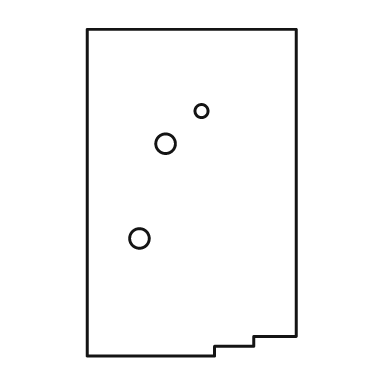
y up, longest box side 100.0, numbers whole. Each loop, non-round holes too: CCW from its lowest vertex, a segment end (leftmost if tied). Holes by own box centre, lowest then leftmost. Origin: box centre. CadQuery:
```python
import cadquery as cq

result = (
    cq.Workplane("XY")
    .moveTo(-32.0, -50.0)
    .lineTo(7.0, -50.0)
    .lineTo(7.0, -47.0)
    .lineTo(19.0, -47.0)
    .lineTo(19.0, -44.0)
    .lineTo(32.0, -44.0)
    .lineTo(32.0, 50.0)
    .lineTo(-32.0, 50.0)
    .close()
    .moveTo(-16.0, -14.0)
    .circle(3.0)
    .moveTo(-8.0, 15.0)
    .circle(3.0)
    .moveTo(3.0, 25.0)
    .circle(2.0)
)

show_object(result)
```